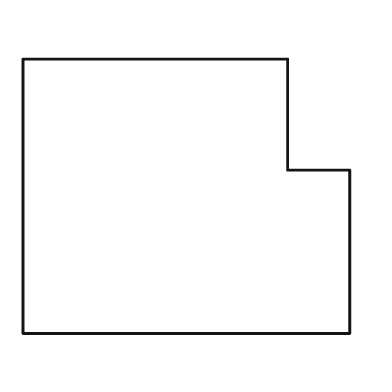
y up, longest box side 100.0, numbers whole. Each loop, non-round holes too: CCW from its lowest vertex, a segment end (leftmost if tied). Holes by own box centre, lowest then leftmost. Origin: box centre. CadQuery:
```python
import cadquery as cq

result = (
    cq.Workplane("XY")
    .moveTo(-50.0, -42.0)
    .lineTo(50.0, -42.0)
    .lineTo(50.0, 8.0)
    .lineTo(31.0, 8.0)
    .lineTo(31.0, 42.0)
    .lineTo(-50.0, 42.0)
    .close()
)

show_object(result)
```